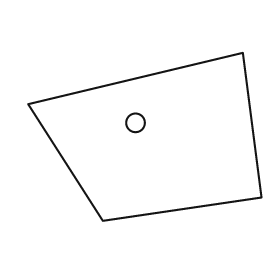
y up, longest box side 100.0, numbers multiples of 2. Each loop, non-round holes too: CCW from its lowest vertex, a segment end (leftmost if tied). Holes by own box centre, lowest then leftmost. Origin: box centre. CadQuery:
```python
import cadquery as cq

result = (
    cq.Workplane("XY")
    .moveTo(-18.0, -36.0)
    .lineTo(50.0, -26.0)
    .lineTo(42.0, 36.0)
    .lineTo(-50.0, 14.0)
    .close()
    .moveTo(-4.0, 6.0)
    .circle(4.0)
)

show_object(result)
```